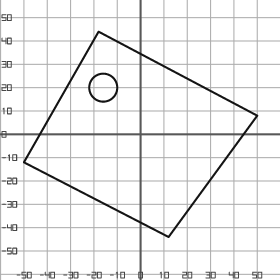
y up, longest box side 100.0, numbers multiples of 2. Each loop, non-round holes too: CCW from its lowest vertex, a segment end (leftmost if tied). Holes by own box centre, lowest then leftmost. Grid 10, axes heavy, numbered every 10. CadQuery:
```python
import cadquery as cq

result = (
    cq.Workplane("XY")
    .moveTo(12.0, -44.0)
    .lineTo(50.0, 8.0)
    .lineTo(-18.0, 44.0)
    .lineTo(-50.0, -12.0)
    .close()
    .moveTo(-16.0, 20.0)
    .circle(6.0)
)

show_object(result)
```